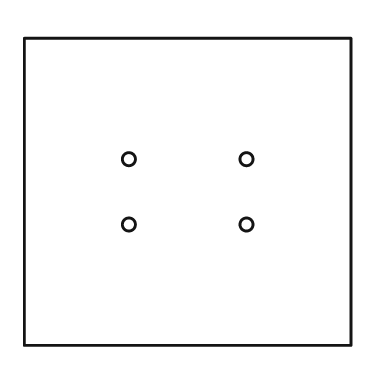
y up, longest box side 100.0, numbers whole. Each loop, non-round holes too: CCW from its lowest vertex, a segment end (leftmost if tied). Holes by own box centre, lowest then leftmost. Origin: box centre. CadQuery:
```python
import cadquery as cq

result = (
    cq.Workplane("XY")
    .moveTo(-50.0, -47.0)
    .lineTo(50.0, -47.0)
    .lineTo(50.0, 47.0)
    .lineTo(-50.0, 47.0)
    .close()
    .moveTo(-18.0, -10.0)
    .circle(2.0)
    .moveTo(18.0, -10.0)
    .circle(2.0)
    .moveTo(-18.0, 10.0)
    .circle(2.0)
    .moveTo(18.0, 10.0)
    .circle(2.0)
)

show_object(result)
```